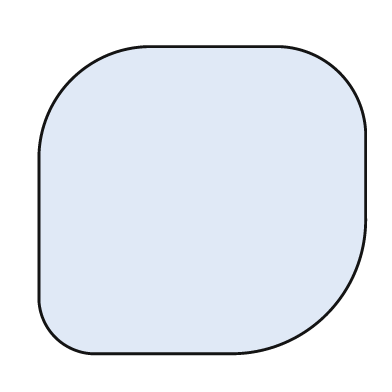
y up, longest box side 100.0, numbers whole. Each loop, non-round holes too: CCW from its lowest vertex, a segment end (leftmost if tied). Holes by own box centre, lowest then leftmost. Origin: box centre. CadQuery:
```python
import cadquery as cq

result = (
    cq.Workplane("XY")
    .moveTo(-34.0, -47.0)
    .lineTo(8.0, -47.0)
    .threePointArc((38.0, -35.0), (50.0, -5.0))
    .lineTo(50.0, 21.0)
    .threePointArc((42.0, 39.0), (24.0, 47.0))
    .lineTo(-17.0, 47.0)
    .threePointArc((-40.0, 37.0), (-50.0, 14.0))
    .lineTo(-50.0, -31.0)
    .threePointArc((-45.0, -42.0), (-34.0, -47.0))
    .close()
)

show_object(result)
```